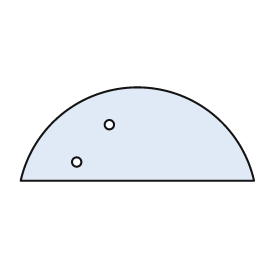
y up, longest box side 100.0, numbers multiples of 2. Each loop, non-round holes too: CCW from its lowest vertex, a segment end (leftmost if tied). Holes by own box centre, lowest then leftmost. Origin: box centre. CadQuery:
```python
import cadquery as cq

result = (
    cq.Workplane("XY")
    .moveTo(-50.0, -20.0)
    .lineTo(50.0, -20.0)
    .threePointArc((0.0, 20.0), (-50.0, -20.0))
    .close()
    .moveTo(-26.0, -12.0)
    .circle(2.0)
    .moveTo(-12.0, 4.0)
    .circle(2.0)
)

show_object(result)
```